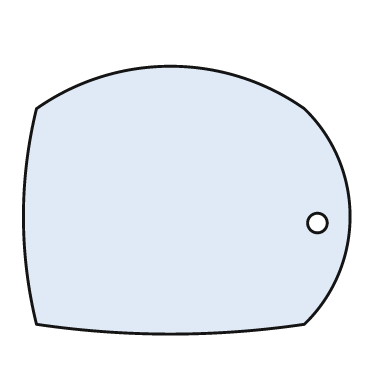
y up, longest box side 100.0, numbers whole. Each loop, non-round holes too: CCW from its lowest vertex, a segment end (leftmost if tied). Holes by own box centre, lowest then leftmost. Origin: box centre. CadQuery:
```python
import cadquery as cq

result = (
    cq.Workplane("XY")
    .moveTo(-46.0, -38.0)
    .threePointArc((-5.0, -41.0), (36.0, -38.0))
    .threePointArc((50.0, -5.0), (36.0, 28.0))
    .threePointArc((-5.0, 41.0), (-46.0, 28.0))
    .threePointArc((-50.0, -5.0), (-46.0, -38.0))
    .close()
    .moveTo(40.0, -7.0)
    .circle(3.0)
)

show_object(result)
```